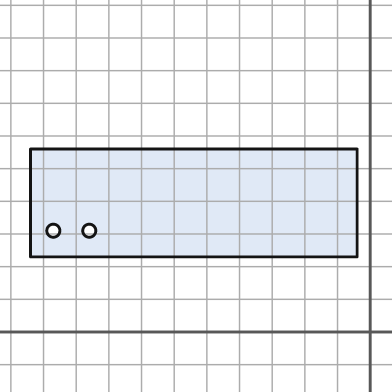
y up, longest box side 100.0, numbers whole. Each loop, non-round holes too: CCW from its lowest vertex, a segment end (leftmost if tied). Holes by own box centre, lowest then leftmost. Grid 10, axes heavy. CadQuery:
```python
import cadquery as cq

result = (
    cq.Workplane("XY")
    .moveTo(-104.0, 23.0)
    .lineTo(-4.0, 23.0)
    .lineTo(-4.0, 56.0)
    .lineTo(-104.0, 56.0)
    .close()
    .moveTo(-97.0, 31.0)
    .circle(2.0)
    .moveTo(-86.0, 31.0)
    .circle(2.0)
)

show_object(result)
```